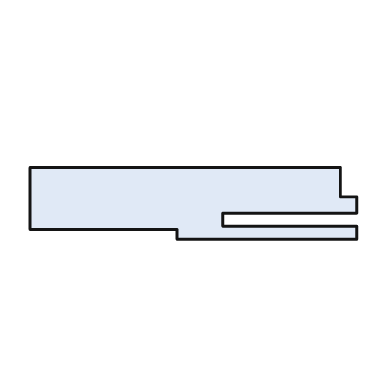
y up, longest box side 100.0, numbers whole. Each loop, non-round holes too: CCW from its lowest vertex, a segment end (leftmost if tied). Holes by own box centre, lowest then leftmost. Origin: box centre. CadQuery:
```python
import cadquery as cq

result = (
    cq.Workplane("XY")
    .moveTo(-5.0, -11.0)
    .lineTo(50.0, -11.0)
    .lineTo(50.0, -7.0)
    .lineTo(9.0, -7.0)
    .lineTo(9.0, -3.0)
    .lineTo(50.0, -3.0)
    .lineTo(50.0, 2.0)
    .lineTo(45.0, 2.0)
    .lineTo(45.0, 11.0)
    .lineTo(-50.0, 11.0)
    .lineTo(-50.0, -8.0)
    .lineTo(-5.0, -8.0)
    .close()
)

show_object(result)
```